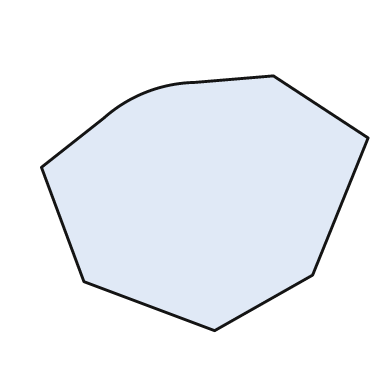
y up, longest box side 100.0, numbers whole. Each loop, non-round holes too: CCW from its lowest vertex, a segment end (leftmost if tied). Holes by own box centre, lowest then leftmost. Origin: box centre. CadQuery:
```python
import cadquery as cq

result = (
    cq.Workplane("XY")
    .moveTo(3.0, -39.0)
    .lineTo(33.0, -22.0)
    .lineTo(50.0, 20.0)
    .lineTo(21.0, 39.0)
    .lineTo(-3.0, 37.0)
    .threePointArc((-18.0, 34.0), (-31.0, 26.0))
    .lineTo(-50.0, 11.0)
    .lineTo(-37.0, -24.0)
    .close()
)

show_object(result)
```